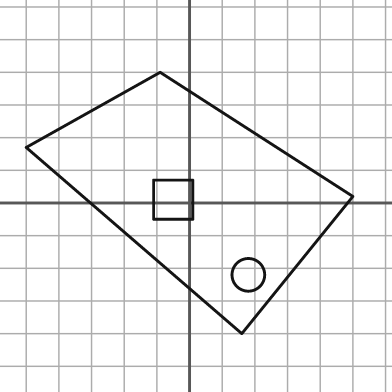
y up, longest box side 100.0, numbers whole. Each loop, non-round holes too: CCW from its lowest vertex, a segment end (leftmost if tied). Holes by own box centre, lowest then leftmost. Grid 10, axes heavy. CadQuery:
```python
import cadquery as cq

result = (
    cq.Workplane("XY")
    .moveTo(16.0, -40.0)
    .lineTo(50.0, 2.0)
    .lineTo(-9.0, 40.0)
    .lineTo(-50.0, 17.0)
    .close()
    .moveTo(18.0, -22.0)
    .circle(5.0)
    .moveTo(-11.0, -5.0)
    .lineTo(1.0, -5.0)
    .lineTo(1.0, 7.0)
    .lineTo(-11.0, 7.0)
    .close()
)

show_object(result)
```